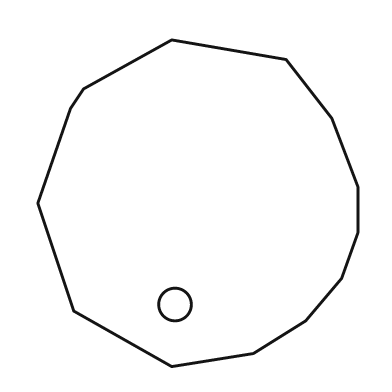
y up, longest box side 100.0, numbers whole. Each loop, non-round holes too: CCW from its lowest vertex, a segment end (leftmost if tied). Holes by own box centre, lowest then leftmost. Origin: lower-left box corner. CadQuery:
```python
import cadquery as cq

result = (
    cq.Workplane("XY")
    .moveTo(41.0, 0.0)
    .lineTo(66.0, 4.0)
    .lineTo(82.0, 14.0)
    .lineTo(93.0, 27.0)
    .lineTo(98.0, 41.0)
    .lineTo(98.0, 55.0)
    .lineTo(90.0, 76.0)
    .lineTo(76.0, 94.0)
    .lineTo(41.0, 100.0)
    .lineTo(14.0, 85.0)
    .lineTo(10.0, 79.0)
    .lineTo(0.0, 50.0)
    .lineTo(11.0, 17.0)
    .close()
    .moveTo(42.0, 19.0)
    .circle(5.0)
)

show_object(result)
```